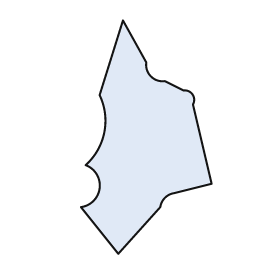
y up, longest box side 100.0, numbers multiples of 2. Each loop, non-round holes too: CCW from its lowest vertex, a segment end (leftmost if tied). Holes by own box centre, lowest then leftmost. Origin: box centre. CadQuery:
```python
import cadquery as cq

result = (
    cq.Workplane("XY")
    .moveTo(-12.0, -50.0)
    .lineTo(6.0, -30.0)
    .threePointArc((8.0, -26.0), (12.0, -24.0))
    .lineTo(28.0, -20.0)
    .lineTo(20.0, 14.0)
    .threePointArc((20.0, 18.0), (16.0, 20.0))
    .lineTo(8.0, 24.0)
    .threePointArc((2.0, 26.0), (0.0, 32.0))
    .lineTo(-10.0, 50.0)
    .lineTo(-20.0, 18.0)
    .threePointArc((-18.0, 2.0), (-26.0, -12.0))
    .threePointArc((-20.0, -22.0), (-28.0, -30.0))
    .close()
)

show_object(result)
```